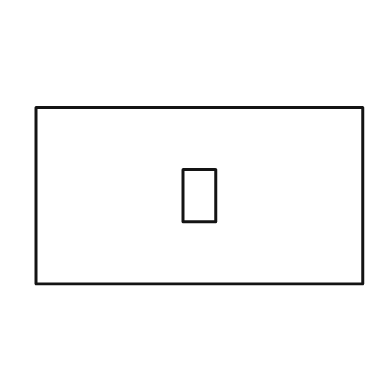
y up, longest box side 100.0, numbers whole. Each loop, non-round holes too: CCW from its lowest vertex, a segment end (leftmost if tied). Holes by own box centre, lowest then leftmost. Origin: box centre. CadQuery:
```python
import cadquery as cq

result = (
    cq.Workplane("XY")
    .moveTo(-50.0, -27.0)
    .lineTo(50.0, -27.0)
    .lineTo(50.0, 27.0)
    .lineTo(-50.0, 27.0)
    .close()
    .moveTo(-5.0, -8.0)
    .lineTo(5.0, -8.0)
    .lineTo(5.0, 8.0)
    .lineTo(-5.0, 8.0)
    .close()
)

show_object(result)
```